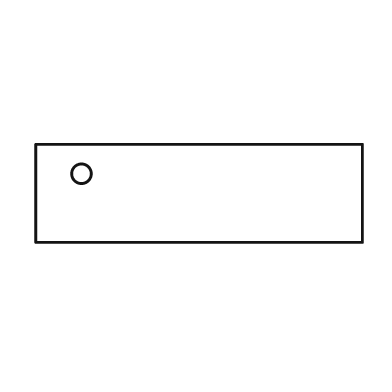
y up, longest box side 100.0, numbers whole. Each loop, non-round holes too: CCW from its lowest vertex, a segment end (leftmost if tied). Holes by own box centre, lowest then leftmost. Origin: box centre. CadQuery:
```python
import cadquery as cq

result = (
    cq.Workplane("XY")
    .moveTo(-50.0, -15.0)
    .lineTo(50.0, -15.0)
    .lineTo(50.0, 15.0)
    .lineTo(-50.0, 15.0)
    .close()
    .moveTo(-36.0, 6.0)
    .circle(3.0)
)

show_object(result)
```